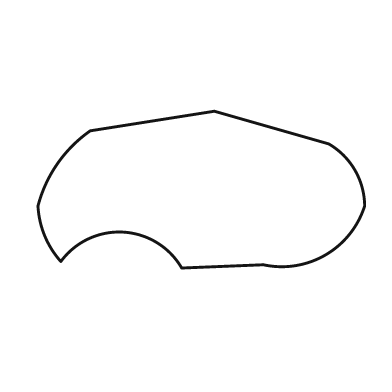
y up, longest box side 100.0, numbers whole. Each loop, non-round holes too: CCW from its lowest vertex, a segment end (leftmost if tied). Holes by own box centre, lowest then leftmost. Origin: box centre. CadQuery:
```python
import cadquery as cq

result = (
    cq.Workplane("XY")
    .moveTo(-6.0, -24.0)
    .lineTo(19.0, -23.0)
    .threePointArc((38.0, -20.0), (50.0, -5.0))
    .threePointArc((47.0, 6.0), (39.0, 14.0))
    .lineTo(4.0, 24.0)
    .lineTo(-34.0, 18.0)
    .threePointArc((-44.0, 8.0), (-50.0, -5.0))
    .threePointArc((-48.0, -14.0), (-43.0, -22.0))
    .threePointArc((-24.0, -13.0), (-6.0, -24.0))
    .close()
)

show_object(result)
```